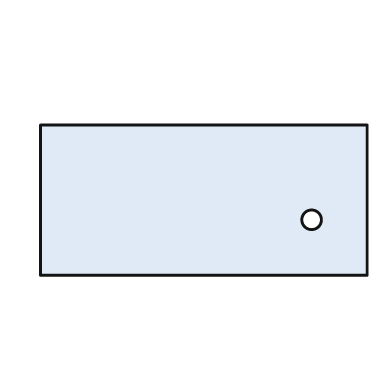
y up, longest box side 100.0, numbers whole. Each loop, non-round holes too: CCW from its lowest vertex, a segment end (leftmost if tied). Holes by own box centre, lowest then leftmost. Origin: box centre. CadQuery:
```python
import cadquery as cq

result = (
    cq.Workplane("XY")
    .moveTo(-50.0, -23.0)
    .lineTo(50.0, -23.0)
    .lineTo(50.0, 23.0)
    .lineTo(-50.0, 23.0)
    .close()
    .moveTo(33.0, -6.0)
    .circle(3.0)
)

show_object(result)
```